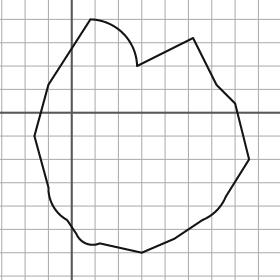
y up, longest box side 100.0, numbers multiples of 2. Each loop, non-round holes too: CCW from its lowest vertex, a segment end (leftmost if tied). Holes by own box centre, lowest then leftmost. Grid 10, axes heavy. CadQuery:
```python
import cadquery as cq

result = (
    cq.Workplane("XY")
    .moveTo(30.0, -60.0)
    .lineTo(44.0, -54.0)
    .lineTo(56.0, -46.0)
    .threePointArc((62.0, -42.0), (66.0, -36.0))
    .lineTo(76.0, -20.0)
    .lineTo(70.0, 4.0)
    .lineTo(62.0, 12.0)
    .lineTo(52.0, 32.0)
    .lineTo(28.0, 20.0)
    .threePointArc((22.0, 34.0), (8.0, 40.0))
    .lineTo(-10.0, 12.0)
    .lineTo(-16.0, -10.0)
    .lineTo(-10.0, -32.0)
    .threePointArc((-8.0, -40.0), (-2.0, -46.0))
    .lineTo(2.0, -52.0)
    .threePointArc((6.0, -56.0), (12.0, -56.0))
    .close()
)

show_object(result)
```